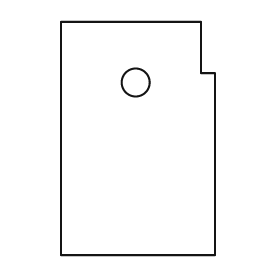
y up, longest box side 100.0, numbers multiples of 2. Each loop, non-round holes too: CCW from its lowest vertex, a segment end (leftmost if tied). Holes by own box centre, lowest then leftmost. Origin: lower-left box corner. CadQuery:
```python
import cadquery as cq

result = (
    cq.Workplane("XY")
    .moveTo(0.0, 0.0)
    .lineTo(66.0, 0.0)
    .lineTo(66.0, 78.0)
    .lineTo(60.0, 78.0)
    .lineTo(60.0, 100.0)
    .lineTo(0.0, 100.0)
    .close()
    .moveTo(32.0, 74.0)
    .circle(6.0)
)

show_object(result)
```